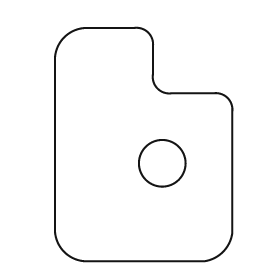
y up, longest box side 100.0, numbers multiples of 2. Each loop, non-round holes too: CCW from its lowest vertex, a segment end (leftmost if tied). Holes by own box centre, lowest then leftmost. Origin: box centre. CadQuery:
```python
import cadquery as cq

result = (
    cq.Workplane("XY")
    .moveTo(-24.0, -50.0)
    .lineTo(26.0, -50.0)
    .threePointArc((34.0, -46.0), (38.0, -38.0))
    .lineTo(38.0, 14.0)
    .threePointArc((36.0, 20.0), (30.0, 22.0))
    .lineTo(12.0, 22.0)
    .threePointArc((6.0, 24.0), (4.0, 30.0))
    .lineTo(4.0, 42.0)
    .threePointArc((2.0, 48.0), (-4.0, 50.0))
    .lineTo(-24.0, 50.0)
    .threePointArc((-34.0, 46.0), (-38.0, 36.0))
    .lineTo(-38.0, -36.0)
    .threePointArc((-34.0, -46.0), (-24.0, -50.0))
    .close()
    .moveTo(8.0, -8.0)
    .circle(10.0)
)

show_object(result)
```